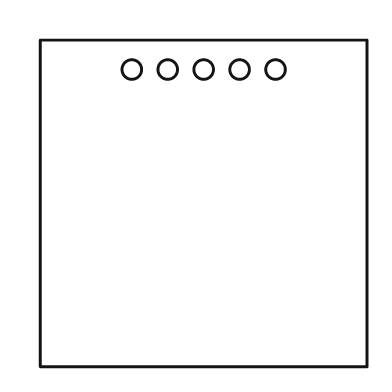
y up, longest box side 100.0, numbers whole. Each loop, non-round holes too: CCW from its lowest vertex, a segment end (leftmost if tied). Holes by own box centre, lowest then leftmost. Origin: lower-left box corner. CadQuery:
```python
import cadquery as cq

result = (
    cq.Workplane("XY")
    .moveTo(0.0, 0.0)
    .lineTo(100.0, 0.0)
    .lineTo(100.0, 100.0)
    .lineTo(0.0, 100.0)
    .close()
    .moveTo(28.0, 91.0)
    .circle(3.0)
    .moveTo(39.0, 91.0)
    .circle(3.0)
    .moveTo(50.0, 91.0)
    .circle(3.0)
    .moveTo(61.0, 91.0)
    .circle(3.0)
    .moveTo(72.0, 91.0)
    .circle(3.0)
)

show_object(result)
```